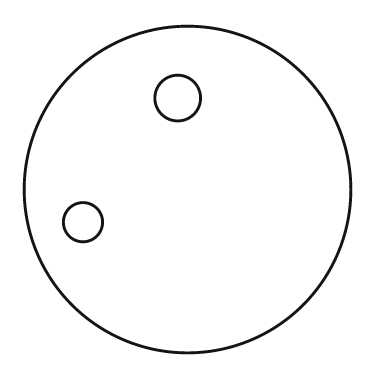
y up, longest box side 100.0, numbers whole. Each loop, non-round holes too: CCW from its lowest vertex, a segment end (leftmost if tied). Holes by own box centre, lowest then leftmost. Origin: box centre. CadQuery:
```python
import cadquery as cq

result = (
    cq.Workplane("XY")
    .moveTo(0.0, 0.0)
    .circle(50.0)
    .moveTo(-32.0, -10.0)
    .circle(6.0)
    .moveTo(-3.0, 28.0)
    .circle(7.0)
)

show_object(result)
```